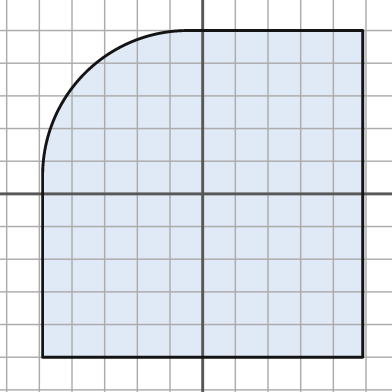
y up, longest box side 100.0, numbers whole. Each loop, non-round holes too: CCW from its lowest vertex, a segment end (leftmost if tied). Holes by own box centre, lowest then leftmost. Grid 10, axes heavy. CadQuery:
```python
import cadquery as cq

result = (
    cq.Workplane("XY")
    .moveTo(-49.0, -50.0)
    .lineTo(49.0, -50.0)
    .lineTo(49.0, 50.0)
    .lineTo(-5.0, 50.0)
    .threePointArc((-36.0, 37.0), (-49.0, 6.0))
    .close()
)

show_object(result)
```